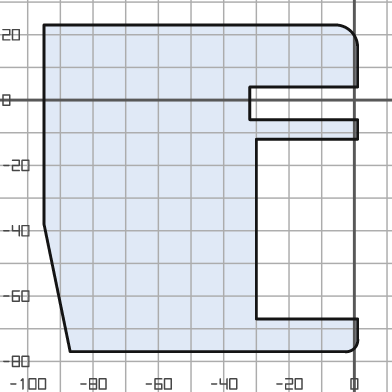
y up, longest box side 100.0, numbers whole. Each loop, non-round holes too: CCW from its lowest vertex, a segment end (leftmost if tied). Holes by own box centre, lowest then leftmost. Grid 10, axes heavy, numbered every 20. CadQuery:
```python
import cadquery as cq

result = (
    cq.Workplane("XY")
    .moveTo(-87.0, -77.0)
    .lineTo(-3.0, -77.0)
    .threePointArc((0.0, -76.0), (1.0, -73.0))
    .lineTo(1.0, -67.0)
    .lineTo(-30.0, -67.0)
    .lineTo(-30.0, -12.0)
    .lineTo(1.0, -12.0)
    .lineTo(1.0, -6.0)
    .lineTo(-32.0, -6.0)
    .lineTo(-32.0, 4.0)
    .lineTo(1.0, 4.0)
    .lineTo(1.0, 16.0)
    .threePointArc((-1.0, 21.0), (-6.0, 23.0))
    .lineTo(-95.0, 23.0)
    .lineTo(-95.0, -38.0)
    .close()
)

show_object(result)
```